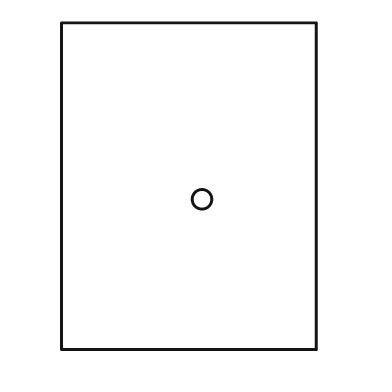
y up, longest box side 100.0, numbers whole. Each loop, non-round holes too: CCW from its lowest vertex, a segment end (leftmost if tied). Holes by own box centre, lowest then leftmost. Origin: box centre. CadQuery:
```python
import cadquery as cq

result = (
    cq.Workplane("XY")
    .moveTo(-39.0, -50.0)
    .lineTo(39.0, -50.0)
    .lineTo(39.0, 50.0)
    .lineTo(-39.0, 50.0)
    .close()
    .moveTo(4.0, -4.0)
    .circle(3.0)
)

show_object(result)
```